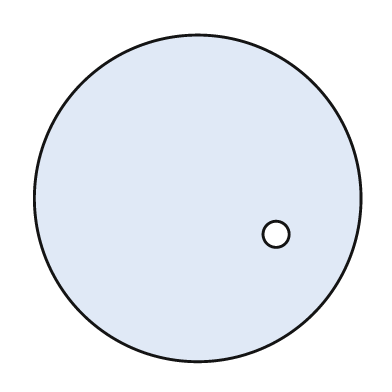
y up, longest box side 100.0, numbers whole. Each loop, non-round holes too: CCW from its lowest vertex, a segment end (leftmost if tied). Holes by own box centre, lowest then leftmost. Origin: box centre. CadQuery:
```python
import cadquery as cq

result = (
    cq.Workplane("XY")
    .moveTo(0.0, 0.0)
    .circle(50.0)
    .moveTo(24.0, -11.0)
    .circle(4.0)
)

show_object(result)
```